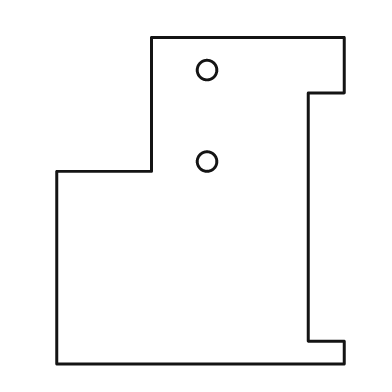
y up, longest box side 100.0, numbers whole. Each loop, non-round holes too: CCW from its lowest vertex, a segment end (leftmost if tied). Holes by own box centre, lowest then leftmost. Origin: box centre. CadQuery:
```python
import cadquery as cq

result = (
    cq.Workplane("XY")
    .moveTo(-44.0, -50.0)
    .lineTo(44.0, -50.0)
    .lineTo(44.0, -43.0)
    .lineTo(33.0, -43.0)
    .lineTo(33.0, 33.0)
    .lineTo(44.0, 33.0)
    .lineTo(44.0, 50.0)
    .lineTo(-15.0, 50.0)
    .lineTo(-15.0, 9.0)
    .lineTo(-44.0, 9.0)
    .close()
    .moveTo(2.0, 12.0)
    .circle(3.0)
    .moveTo(2.0, 40.0)
    .circle(3.0)
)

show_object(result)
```